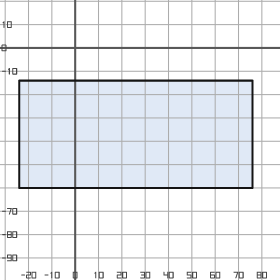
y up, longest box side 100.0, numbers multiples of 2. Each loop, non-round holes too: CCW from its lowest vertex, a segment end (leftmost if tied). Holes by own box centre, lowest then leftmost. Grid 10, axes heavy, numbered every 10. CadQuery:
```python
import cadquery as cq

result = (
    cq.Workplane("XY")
    .moveTo(-24.0, -60.0)
    .lineTo(76.0, -60.0)
    .lineTo(76.0, -14.0)
    .lineTo(-24.0, -14.0)
    .close()
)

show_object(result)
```